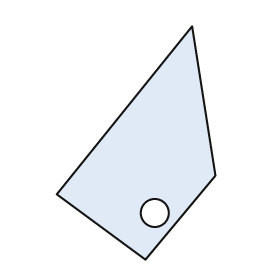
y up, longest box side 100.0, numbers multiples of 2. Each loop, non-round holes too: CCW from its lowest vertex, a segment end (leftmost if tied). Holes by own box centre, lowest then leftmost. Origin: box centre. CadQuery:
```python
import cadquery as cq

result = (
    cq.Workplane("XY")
    .moveTo(4.0, -50.0)
    .lineTo(34.0, -14.0)
    .lineTo(24.0, 50.0)
    .lineTo(-34.0, -22.0)
    .close()
    .moveTo(8.0, -30.0)
    .circle(6.0)
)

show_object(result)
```